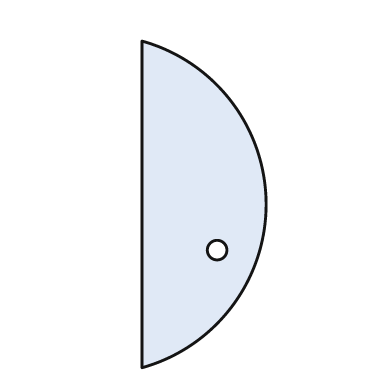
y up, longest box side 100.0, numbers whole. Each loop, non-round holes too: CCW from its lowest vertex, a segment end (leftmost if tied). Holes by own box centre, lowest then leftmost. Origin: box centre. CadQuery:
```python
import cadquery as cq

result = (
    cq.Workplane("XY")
    .moveTo(-19.0, -50.0)
    .threePointArc((19.0, 0.0), (-19.0, 50.0))
    .close()
    .moveTo(4.0, -14.0)
    .circle(3.0)
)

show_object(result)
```